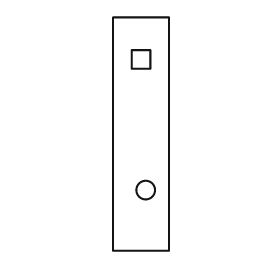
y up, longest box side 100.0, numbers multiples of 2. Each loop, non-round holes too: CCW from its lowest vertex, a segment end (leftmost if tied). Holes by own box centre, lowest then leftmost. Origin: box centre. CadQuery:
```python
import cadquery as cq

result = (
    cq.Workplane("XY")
    .moveTo(-12.0, -50.0)
    .lineTo(12.0, -50.0)
    .lineTo(12.0, 50.0)
    .lineTo(-12.0, 50.0)
    .close()
    .moveTo(2.0, -24.0)
    .circle(4.0)
    .moveTo(-4.0, 28.0)
    .lineTo(4.0, 28.0)
    .lineTo(4.0, 36.0)
    .lineTo(-4.0, 36.0)
    .close()
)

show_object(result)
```